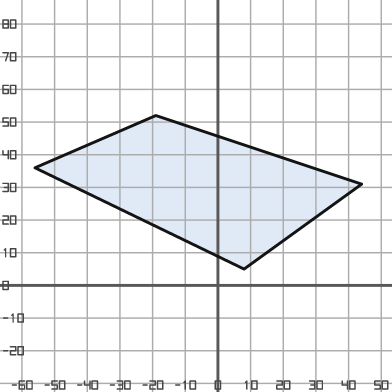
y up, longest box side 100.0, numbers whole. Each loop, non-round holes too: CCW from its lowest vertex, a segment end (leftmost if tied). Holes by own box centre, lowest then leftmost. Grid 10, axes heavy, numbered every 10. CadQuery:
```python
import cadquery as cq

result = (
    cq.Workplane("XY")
    .moveTo(8.0, 5.0)
    .lineTo(44.0, 31.0)
    .lineTo(-19.0, 52.0)
    .lineTo(-56.0, 36.0)
    .close()
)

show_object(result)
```